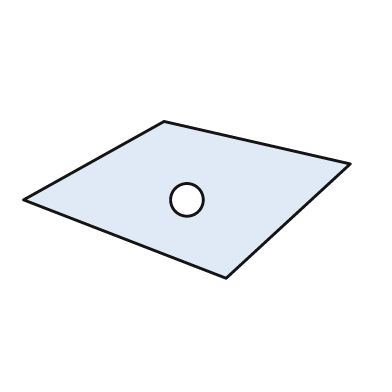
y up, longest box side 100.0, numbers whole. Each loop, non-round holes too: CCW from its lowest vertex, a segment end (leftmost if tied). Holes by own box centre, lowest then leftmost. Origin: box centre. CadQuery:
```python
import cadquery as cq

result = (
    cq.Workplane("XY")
    .moveTo(12.0, -24.0)
    .lineTo(50.0, 11.0)
    .lineTo(-7.0, 24.0)
    .lineTo(-50.0, 0.0)
    .close()
    .moveTo(0.0, 0.0)
    .circle(5.0)
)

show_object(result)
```